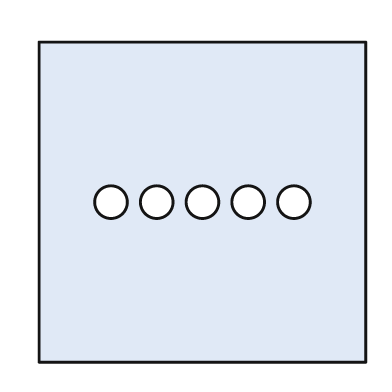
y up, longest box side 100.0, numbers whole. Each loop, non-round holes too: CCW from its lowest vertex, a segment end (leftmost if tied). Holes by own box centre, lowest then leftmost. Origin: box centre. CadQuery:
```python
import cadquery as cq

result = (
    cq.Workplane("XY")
    .moveTo(-50.0, -49.0)
    .lineTo(50.0, -49.0)
    .lineTo(50.0, 49.0)
    .lineTo(-50.0, 49.0)
    .close()
    .moveTo(-28.0, 0.0)
    .circle(5.0)
    .moveTo(-14.0, 0.0)
    .circle(5.0)
    .moveTo(0.0, 0.0)
    .circle(5.0)
    .moveTo(14.0, 0.0)
    .circle(5.0)
    .moveTo(28.0, 0.0)
    .circle(5.0)
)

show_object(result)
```